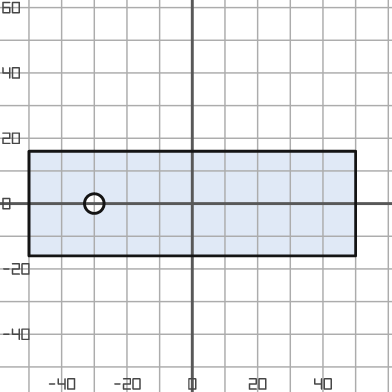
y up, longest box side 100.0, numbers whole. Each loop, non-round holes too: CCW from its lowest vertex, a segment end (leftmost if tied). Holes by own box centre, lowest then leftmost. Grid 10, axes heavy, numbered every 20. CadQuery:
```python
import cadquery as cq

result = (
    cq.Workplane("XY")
    .moveTo(-50.0, -16.0)
    .lineTo(50.0, -16.0)
    .lineTo(50.0, 16.0)
    .lineTo(-50.0, 16.0)
    .close()
    .moveTo(-30.0, 0.0)
    .circle(3.0)
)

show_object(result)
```